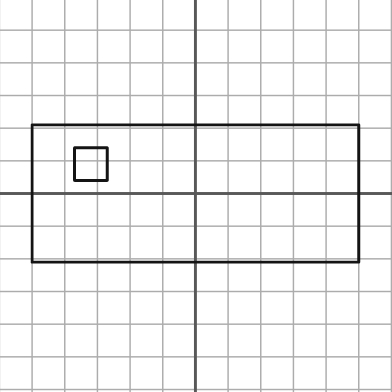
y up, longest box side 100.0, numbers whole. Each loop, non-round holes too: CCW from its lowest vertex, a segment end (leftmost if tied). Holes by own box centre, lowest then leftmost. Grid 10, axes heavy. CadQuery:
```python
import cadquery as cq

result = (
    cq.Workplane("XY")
    .moveTo(-50.0, -21.0)
    .lineTo(50.0, -21.0)
    .lineTo(50.0, 21.0)
    .lineTo(-50.0, 21.0)
    .close()
    .moveTo(-37.0, 4.0)
    .lineTo(-27.0, 4.0)
    .lineTo(-27.0, 14.0)
    .lineTo(-37.0, 14.0)
    .close()
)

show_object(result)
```